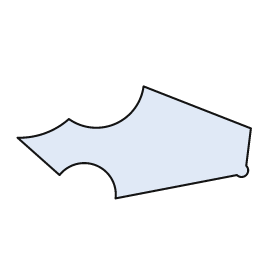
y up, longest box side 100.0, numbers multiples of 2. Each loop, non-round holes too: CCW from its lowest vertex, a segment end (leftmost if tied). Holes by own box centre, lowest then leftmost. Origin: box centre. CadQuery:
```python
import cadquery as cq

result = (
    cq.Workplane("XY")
    .moveTo(-8.0, -24.0)
    .lineTo(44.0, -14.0)
    .threePointArc((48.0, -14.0), (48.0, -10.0))
    .lineTo(50.0, 6.0)
    .lineTo(4.0, 24.0)
    .threePointArc((-8.0, 8.0), (-28.0, 10.0))
    .threePointArc((-38.0, 4.0), (-50.0, 2.0))
    .lineTo(-32.0, -14.0)
    .threePointArc((-16.0, -10.0), (-8.0, -24.0))
    .close()
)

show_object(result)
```